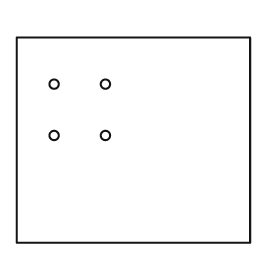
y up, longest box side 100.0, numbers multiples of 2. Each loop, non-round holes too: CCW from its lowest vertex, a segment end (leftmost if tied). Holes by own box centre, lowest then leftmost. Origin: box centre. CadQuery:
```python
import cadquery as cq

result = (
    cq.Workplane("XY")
    .moveTo(-50.0, -44.0)
    .lineTo(50.0, -44.0)
    .lineTo(50.0, 44.0)
    .lineTo(-50.0, 44.0)
    .close()
    .moveTo(-34.0, 2.0)
    .circle(2.0)
    .moveTo(-12.0, 2.0)
    .circle(2.0)
    .moveTo(-34.0, 24.0)
    .circle(2.0)
    .moveTo(-12.0, 24.0)
    .circle(2.0)
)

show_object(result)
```